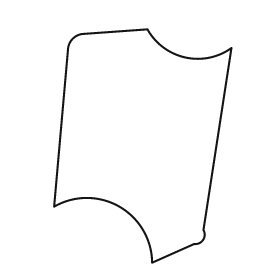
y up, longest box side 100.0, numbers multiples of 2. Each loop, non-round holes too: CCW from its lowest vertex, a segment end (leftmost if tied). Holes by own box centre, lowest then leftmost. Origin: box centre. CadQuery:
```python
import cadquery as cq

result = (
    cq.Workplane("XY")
    .moveTo(4.0, -50.0)
    .lineTo(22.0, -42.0)
    .threePointArc((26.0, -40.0), (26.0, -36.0))
    .lineTo(38.0, 42.0)
    .threePointArc((18.0, 38.0), (2.0, 50.0))
    .lineTo(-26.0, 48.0)
    .threePointArc((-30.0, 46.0), (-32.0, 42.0))
    .lineTo(-38.0, -26.0)
    .threePointArc((-10.0, -26.0), (4.0, -50.0))
    .close()
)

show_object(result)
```